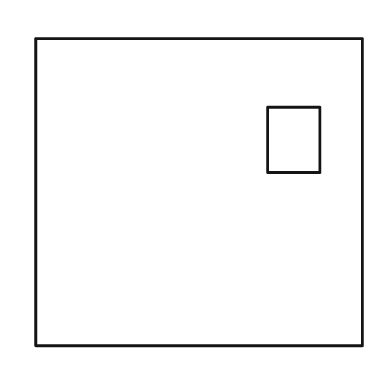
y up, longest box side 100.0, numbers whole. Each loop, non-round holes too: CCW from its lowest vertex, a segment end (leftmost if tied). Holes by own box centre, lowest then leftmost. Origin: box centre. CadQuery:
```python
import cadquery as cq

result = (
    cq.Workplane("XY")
    .moveTo(-50.0, -47.0)
    .lineTo(50.0, -47.0)
    .lineTo(50.0, 47.0)
    .lineTo(-50.0, 47.0)
    .close()
    .moveTo(21.0, 6.0)
    .lineTo(37.0, 6.0)
    .lineTo(37.0, 26.0)
    .lineTo(21.0, 26.0)
    .close()
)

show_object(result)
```